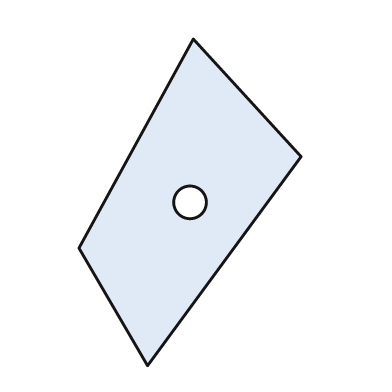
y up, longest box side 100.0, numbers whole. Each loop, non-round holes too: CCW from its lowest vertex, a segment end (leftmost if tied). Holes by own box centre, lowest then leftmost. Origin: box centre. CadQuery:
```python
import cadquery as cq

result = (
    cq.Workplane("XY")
    .moveTo(-13.0, -50.0)
    .lineTo(34.0, 14.0)
    .lineTo(1.0, 50.0)
    .lineTo(-34.0, -14.0)
    .close()
    .moveTo(0.0, 0.0)
    .circle(5.0)
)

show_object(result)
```